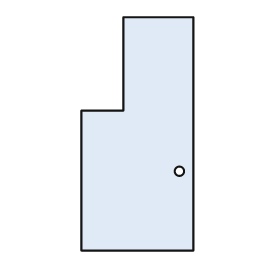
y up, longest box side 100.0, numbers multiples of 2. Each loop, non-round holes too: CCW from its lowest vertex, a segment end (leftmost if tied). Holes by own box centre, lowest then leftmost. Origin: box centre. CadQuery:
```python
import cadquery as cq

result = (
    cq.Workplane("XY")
    .moveTo(-24.0, -50.0)
    .lineTo(24.0, -50.0)
    .lineTo(24.0, 50.0)
    .lineTo(-6.0, 50.0)
    .lineTo(-6.0, 10.0)
    .lineTo(-24.0, 10.0)
    .close()
    .moveTo(18.0, -16.0)
    .circle(2.0)
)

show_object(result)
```